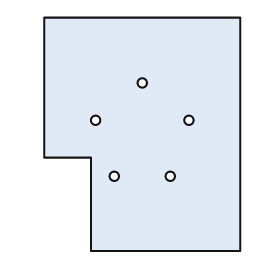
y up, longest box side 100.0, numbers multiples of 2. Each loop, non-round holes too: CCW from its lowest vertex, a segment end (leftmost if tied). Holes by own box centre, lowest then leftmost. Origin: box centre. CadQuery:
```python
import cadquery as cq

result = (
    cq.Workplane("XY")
    .moveTo(-22.0, -50.0)
    .lineTo(42.0, -50.0)
    .lineTo(42.0, 50.0)
    .lineTo(-42.0, 50.0)
    .lineTo(-42.0, -10.0)
    .lineTo(-22.0, -10.0)
    .close()
    .moveTo(-12.0, -18.0)
    .circle(2.0)
    .moveTo(12.0, -18.0)
    .circle(2.0)
    .moveTo(-20.0, 6.0)
    .circle(2.0)
    .moveTo(20.0, 6.0)
    .circle(2.0)
    .moveTo(0.0, 22.0)
    .circle(2.0)
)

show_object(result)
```